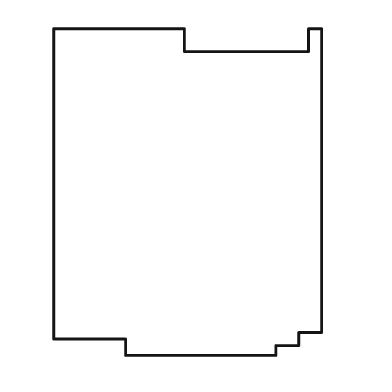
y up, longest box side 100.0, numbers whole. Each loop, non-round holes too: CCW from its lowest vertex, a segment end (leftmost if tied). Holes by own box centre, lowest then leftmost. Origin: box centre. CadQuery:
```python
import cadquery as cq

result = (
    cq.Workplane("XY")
    .moveTo(-19.0, -50.0)
    .lineTo(27.0, -50.0)
    .lineTo(27.0, -47.0)
    .lineTo(34.0, -47.0)
    .lineTo(34.0, -43.0)
    .lineTo(41.0, -43.0)
    .lineTo(41.0, 50.0)
    .lineTo(37.0, 50.0)
    .lineTo(37.0, 43.0)
    .lineTo(-1.0, 43.0)
    .lineTo(-1.0, 50.0)
    .lineTo(-41.0, 50.0)
    .lineTo(-41.0, -45.0)
    .lineTo(-19.0, -45.0)
    .close()
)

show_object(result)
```